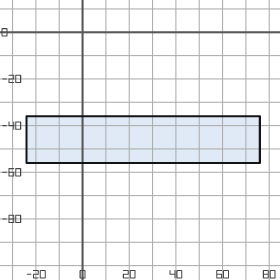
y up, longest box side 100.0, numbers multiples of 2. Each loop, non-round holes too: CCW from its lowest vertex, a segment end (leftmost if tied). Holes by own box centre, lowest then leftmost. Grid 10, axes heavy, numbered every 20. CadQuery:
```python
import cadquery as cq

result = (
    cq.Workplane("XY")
    .moveTo(-24.0, -56.0)
    .lineTo(76.0, -56.0)
    .lineTo(76.0, -36.0)
    .lineTo(-24.0, -36.0)
    .close()
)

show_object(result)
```